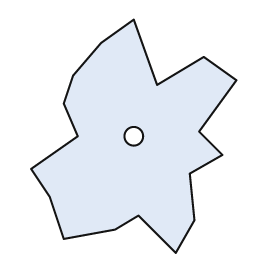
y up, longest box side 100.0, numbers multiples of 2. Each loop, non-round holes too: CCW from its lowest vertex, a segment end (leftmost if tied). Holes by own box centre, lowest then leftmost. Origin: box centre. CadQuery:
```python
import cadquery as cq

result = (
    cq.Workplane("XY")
    .moveTo(18.0, -50.0)
    .lineTo(26.0, -36.0)
    .lineTo(24.0, -16.0)
    .lineTo(38.0, -8.0)
    .lineTo(28.0, 2.0)
    .lineTo(44.0, 24.0)
    .lineTo(30.0, 34.0)
    .lineTo(10.0, 22.0)
    .lineTo(0.0, 50.0)
    .lineTo(-14.0, 40.0)
    .lineTo(-26.0, 26.0)
    .lineTo(-30.0, 14.0)
    .lineTo(-24.0, 0.0)
    .lineTo(-44.0, -14.0)
    .lineTo(-36.0, -26.0)
    .lineTo(-30.0, -44.0)
    .lineTo(-8.0, -40.0)
    .lineTo(2.0, -34.0)
    .close()
    .moveTo(0.0, 0.0)
    .circle(4.0)
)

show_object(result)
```